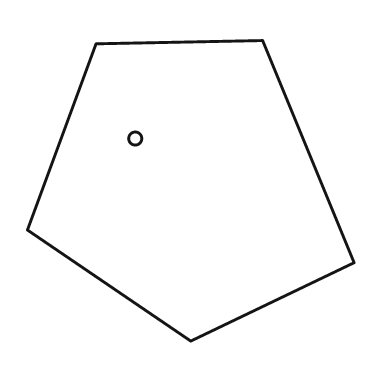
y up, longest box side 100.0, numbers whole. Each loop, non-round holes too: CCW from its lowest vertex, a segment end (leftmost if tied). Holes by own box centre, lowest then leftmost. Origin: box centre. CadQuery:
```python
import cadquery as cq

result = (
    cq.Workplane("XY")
    .moveTo(0.0, -46.0)
    .lineTo(50.0, -22.0)
    .lineTo(22.0, 46.0)
    .lineTo(-29.0, 45.0)
    .lineTo(-50.0, -12.0)
    .close()
    .moveTo(-17.0, 16.0)
    .circle(2.0)
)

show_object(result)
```